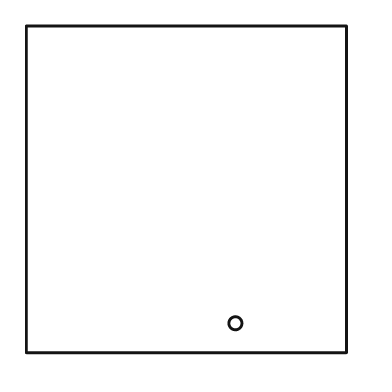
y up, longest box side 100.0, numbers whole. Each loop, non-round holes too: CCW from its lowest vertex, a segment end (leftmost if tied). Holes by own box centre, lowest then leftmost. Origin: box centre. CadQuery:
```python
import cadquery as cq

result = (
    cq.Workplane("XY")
    .moveTo(-49.0, -50.0)
    .lineTo(49.0, -50.0)
    .lineTo(49.0, 50.0)
    .lineTo(-49.0, 50.0)
    .close()
    .moveTo(15.0, -41.0)
    .circle(2.0)
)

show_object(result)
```